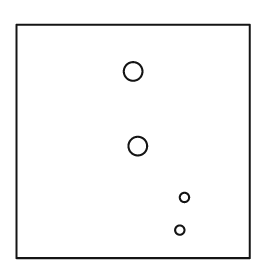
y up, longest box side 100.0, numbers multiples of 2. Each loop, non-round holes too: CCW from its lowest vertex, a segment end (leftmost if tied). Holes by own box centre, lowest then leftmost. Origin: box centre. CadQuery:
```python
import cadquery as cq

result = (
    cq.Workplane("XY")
    .moveTo(-50.0, -50.0)
    .lineTo(50.0, -50.0)
    .lineTo(50.0, 50.0)
    .lineTo(-50.0, 50.0)
    .close()
    .moveTo(20.0, -38.0)
    .circle(2.0)
    .moveTo(22.0, -24.0)
    .circle(2.0)
    .moveTo(2.0, -2.0)
    .circle(4.0)
    .moveTo(0.0, 30.0)
    .circle(4.0)
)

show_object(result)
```